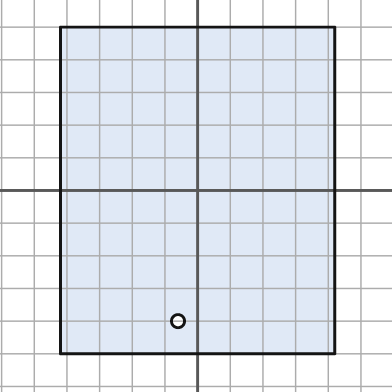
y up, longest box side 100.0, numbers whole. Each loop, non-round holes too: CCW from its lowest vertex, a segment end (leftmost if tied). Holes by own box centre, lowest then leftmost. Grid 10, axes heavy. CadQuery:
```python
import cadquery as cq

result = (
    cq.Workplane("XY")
    .moveTo(-42.0, -50.0)
    .lineTo(42.0, -50.0)
    .lineTo(42.0, 50.0)
    .lineTo(-42.0, 50.0)
    .close()
    .moveTo(-6.0, -40.0)
    .circle(2.0)
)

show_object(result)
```